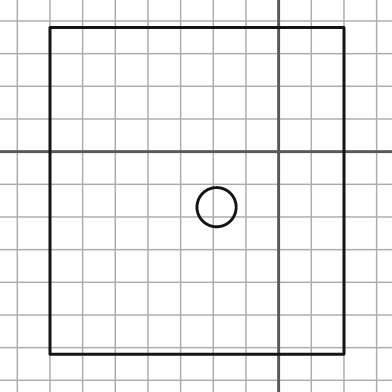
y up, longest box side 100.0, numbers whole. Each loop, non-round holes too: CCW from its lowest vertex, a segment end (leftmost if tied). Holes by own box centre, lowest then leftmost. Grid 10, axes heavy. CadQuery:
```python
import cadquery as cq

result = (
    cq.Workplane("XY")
    .moveTo(-70.0, -62.0)
    .lineTo(20.0, -62.0)
    .lineTo(20.0, 38.0)
    .lineTo(-70.0, 38.0)
    .close()
    .moveTo(-19.0, -17.0)
    .circle(6.0)
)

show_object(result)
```